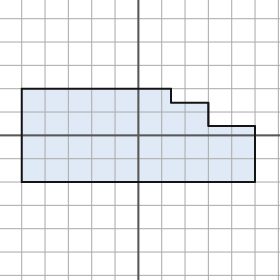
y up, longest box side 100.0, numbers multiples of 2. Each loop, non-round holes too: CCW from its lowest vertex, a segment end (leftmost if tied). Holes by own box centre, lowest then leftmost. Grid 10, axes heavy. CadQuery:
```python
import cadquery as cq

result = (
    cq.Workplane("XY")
    .moveTo(-50.0, -20.0)
    .lineTo(50.0, -20.0)
    .lineTo(50.0, 4.0)
    .lineTo(30.0, 4.0)
    .lineTo(30.0, 14.0)
    .lineTo(14.0, 14.0)
    .lineTo(14.0, 20.0)
    .lineTo(-50.0, 20.0)
    .close()
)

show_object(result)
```